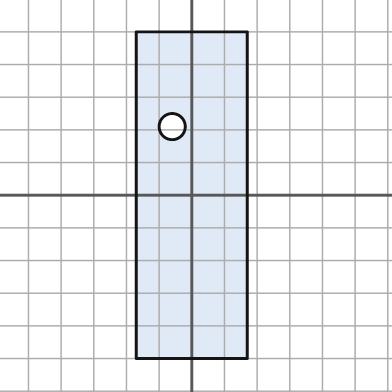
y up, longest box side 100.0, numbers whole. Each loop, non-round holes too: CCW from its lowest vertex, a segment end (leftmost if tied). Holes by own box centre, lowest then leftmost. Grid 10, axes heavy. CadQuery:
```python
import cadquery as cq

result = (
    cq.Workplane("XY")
    .moveTo(-17.0, -50.0)
    .lineTo(17.0, -50.0)
    .lineTo(17.0, 50.0)
    .lineTo(-17.0, 50.0)
    .close()
    .moveTo(-6.0, 21.0)
    .circle(4.0)
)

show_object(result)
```